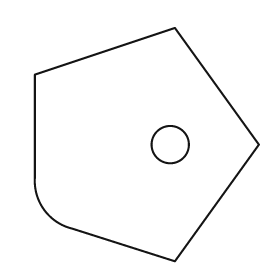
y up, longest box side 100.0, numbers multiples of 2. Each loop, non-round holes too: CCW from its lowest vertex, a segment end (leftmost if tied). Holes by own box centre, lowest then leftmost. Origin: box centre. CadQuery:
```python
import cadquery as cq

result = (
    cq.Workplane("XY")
    .moveTo(12.0, -50.0)
    .lineTo(48.0, 0.0)
    .lineTo(12.0, 50.0)
    .lineTo(-48.0, 30.0)
    .lineTo(-48.0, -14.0)
    .threePointArc((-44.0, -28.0), (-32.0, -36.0))
    .close()
    .moveTo(10.0, 0.0)
    .circle(8.0)
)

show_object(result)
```